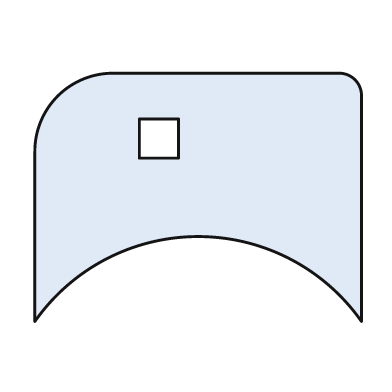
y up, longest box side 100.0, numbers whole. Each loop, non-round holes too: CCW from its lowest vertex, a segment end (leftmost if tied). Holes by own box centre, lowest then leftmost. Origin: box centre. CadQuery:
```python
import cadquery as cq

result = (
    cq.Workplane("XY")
    .moveTo(-50.0, -38.0)
    .threePointArc((0.0, -12.0), (50.0, -38.0))
    .lineTo(50.0, 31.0)
    .threePointArc((48.0, 36.0), (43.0, 38.0))
    .lineTo(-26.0, 38.0)
    .threePointArc((-43.0, 31.0), (-50.0, 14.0))
    .close()
    .moveTo(-18.0, 12.0)
    .lineTo(-6.0, 12.0)
    .lineTo(-6.0, 24.0)
    .lineTo(-18.0, 24.0)
    .close()
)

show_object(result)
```